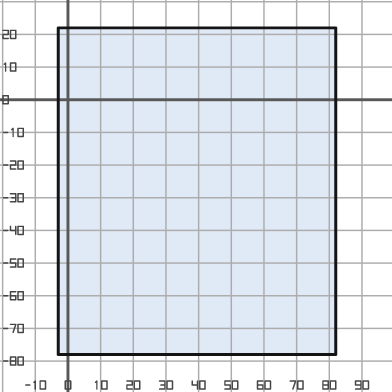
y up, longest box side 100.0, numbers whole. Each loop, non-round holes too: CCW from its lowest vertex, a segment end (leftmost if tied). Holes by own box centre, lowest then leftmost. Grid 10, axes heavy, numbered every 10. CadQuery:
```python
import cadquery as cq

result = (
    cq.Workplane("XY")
    .moveTo(-3.0, -78.0)
    .lineTo(82.0, -78.0)
    .lineTo(82.0, 22.0)
    .lineTo(-3.0, 22.0)
    .close()
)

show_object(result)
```